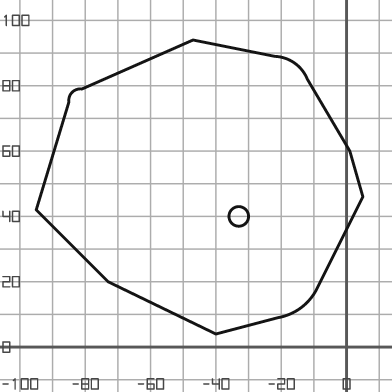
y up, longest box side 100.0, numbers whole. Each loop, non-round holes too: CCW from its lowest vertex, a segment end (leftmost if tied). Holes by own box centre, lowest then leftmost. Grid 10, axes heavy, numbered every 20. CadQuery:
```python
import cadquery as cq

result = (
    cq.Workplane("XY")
    .moveTo(-40.0, 4.0)
    .lineTo(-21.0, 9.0)
    .threePointArc((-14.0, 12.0), (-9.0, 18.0))
    .lineTo(5.0, 46.0)
    .lineTo(1.0, 60.0)
    .lineTo(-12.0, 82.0)
    .threePointArc((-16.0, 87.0), (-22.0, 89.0))
    .lineTo(-47.0, 94.0)
    .lineTo(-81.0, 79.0)
    .threePointArc((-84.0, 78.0), (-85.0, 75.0))
    .lineTo(-95.0, 42.0)
    .lineTo(-73.0, 20.0)
    .close()
    .moveTo(-33.0, 40.0)
    .circle(3.0)
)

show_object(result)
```